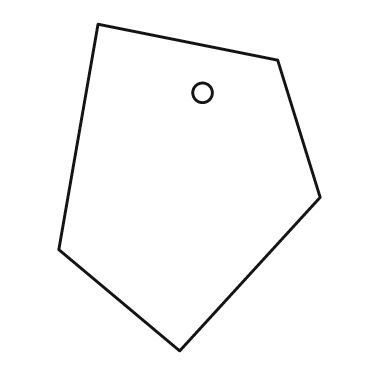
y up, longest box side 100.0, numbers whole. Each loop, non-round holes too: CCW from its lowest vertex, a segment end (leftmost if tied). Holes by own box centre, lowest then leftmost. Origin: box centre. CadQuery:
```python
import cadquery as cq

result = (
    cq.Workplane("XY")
    .moveTo(-3.0, -50.0)
    .lineTo(40.0, -3.0)
    .lineTo(27.0, 39.0)
    .lineTo(-28.0, 50.0)
    .lineTo(-40.0, -19.0)
    .close()
    .moveTo(4.0, 29.0)
    .circle(3.0)
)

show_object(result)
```